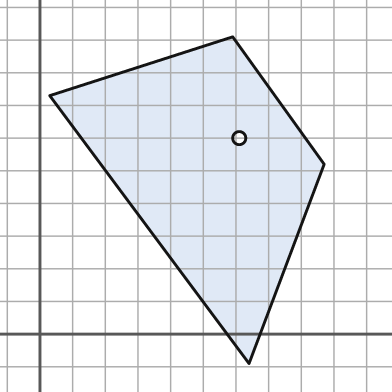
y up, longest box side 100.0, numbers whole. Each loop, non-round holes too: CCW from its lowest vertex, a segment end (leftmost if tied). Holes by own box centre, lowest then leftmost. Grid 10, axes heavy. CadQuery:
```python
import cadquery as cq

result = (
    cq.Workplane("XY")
    .moveTo(64.0, -9.0)
    .lineTo(87.0, 52.0)
    .lineTo(59.0, 91.0)
    .lineTo(3.0, 73.0)
    .close()
    .moveTo(61.0, 60.0)
    .circle(2.0)
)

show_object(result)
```